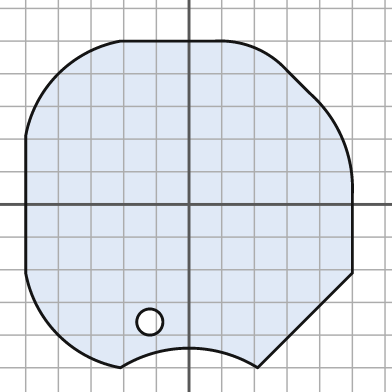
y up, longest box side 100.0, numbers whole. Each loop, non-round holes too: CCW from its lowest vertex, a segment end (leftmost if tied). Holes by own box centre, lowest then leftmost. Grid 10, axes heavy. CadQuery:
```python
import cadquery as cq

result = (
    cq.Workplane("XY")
    .moveTo(-21.0, -50.0)
    .threePointArc((0.0, -44.0), (21.0, -50.0))
    .lineTo(50.0, -21.0)
    .lineTo(50.0, 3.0)
    .threePointArc((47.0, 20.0), (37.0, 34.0))
    .lineTo(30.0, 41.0)
    .threePointArc((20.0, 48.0), (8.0, 50.0))
    .lineTo(-21.0, 50.0)
    .threePointArc((-40.0, 40.0), (-50.0, 21.0))
    .lineTo(-50.0, -21.0)
    .threePointArc((-40.0, -40.0), (-21.0, -50.0))
    .close()
    .moveTo(-12.0, -36.0)
    .circle(4.0)
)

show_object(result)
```